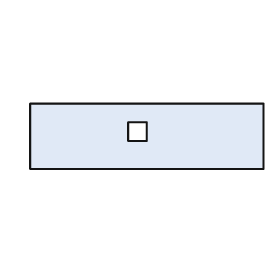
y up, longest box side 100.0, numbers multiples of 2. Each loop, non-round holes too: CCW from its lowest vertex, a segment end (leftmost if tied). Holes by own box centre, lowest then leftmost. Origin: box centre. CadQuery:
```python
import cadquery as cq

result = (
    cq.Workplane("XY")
    .moveTo(-50.0, -14.0)
    .lineTo(50.0, -14.0)
    .lineTo(50.0, 14.0)
    .lineTo(-50.0, 14.0)
    .close()
    .moveTo(-8.0, -2.0)
    .lineTo(0.0, -2.0)
    .lineTo(0.0, 6.0)
    .lineTo(-8.0, 6.0)
    .close()
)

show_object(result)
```